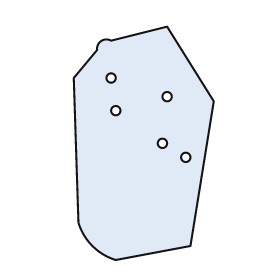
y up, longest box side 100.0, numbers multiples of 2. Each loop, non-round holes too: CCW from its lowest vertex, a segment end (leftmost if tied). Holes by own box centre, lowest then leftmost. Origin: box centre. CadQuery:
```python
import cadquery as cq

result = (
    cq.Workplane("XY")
    .moveTo(-12.0, -50.0)
    .lineTo(20.0, -44.0)
    .lineTo(30.0, 18.0)
    .lineTo(10.0, 50.0)
    .lineTo(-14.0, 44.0)
    .threePointArc((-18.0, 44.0), (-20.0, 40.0))
    .lineTo(-30.0, 28.0)
    .lineTo(-28.0, -34.0)
    .threePointArc((-22.0, -44.0), (-12.0, -50.0))
    .close()
    .moveTo(18.0, -6.0)
    .circle(2.0)
    .moveTo(8.0, 0.0)
    .circle(2.0)
    .moveTo(-12.0, 14.0)
    .circle(2.0)
    .moveTo(10.0, 20.0)
    .circle(2.0)
    .moveTo(-14.0, 28.0)
    .circle(2.0)
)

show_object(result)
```